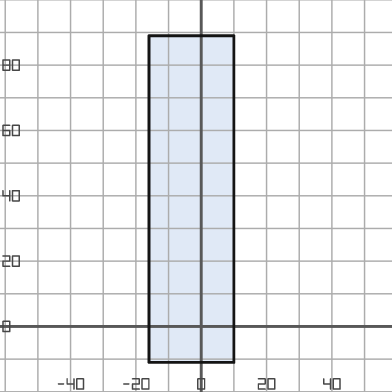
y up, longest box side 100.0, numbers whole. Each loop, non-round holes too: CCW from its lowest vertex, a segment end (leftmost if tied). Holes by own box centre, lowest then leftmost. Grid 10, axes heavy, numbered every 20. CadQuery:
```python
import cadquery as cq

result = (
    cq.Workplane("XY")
    .moveTo(-16.0, -11.0)
    .lineTo(10.0, -11.0)
    .lineTo(10.0, 89.0)
    .lineTo(-16.0, 89.0)
    .close()
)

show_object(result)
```